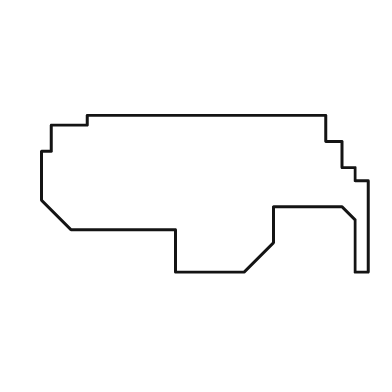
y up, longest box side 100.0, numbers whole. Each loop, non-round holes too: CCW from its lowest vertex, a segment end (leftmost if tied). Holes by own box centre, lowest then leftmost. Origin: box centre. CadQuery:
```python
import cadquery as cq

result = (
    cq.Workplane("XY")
    .moveTo(-9.0, -24.0)
    .lineTo(12.0, -24.0)
    .lineTo(21.0, -15.0)
    .lineTo(21.0, -4.0)
    .lineTo(42.0, -4.0)
    .lineTo(46.0, -8.0)
    .lineTo(46.0, -24.0)
    .lineTo(50.0, -24.0)
    .lineTo(50.0, 4.0)
    .lineTo(46.0, 4.0)
    .lineTo(46.0, 8.0)
    .lineTo(42.0, 8.0)
    .lineTo(42.0, 16.0)
    .lineTo(37.0, 16.0)
    .lineTo(37.0, 24.0)
    .lineTo(-36.0, 24.0)
    .lineTo(-36.0, 21.0)
    .lineTo(-47.0, 21.0)
    .lineTo(-47.0, 13.0)
    .lineTo(-50.0, 13.0)
    .lineTo(-50.0, -2.0)
    .lineTo(-41.0, -11.0)
    .lineTo(-9.0, -11.0)
    .close()
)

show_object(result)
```